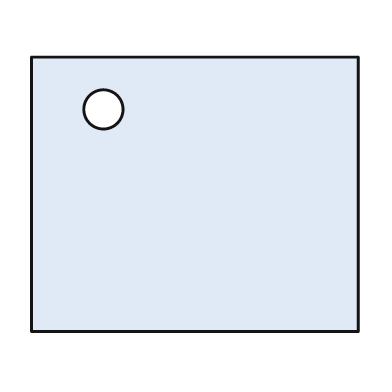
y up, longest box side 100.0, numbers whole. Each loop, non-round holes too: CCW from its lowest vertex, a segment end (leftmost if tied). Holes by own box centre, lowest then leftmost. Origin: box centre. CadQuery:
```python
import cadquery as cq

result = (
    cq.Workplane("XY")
    .moveTo(-50.0, -42.0)
    .lineTo(50.0, -42.0)
    .lineTo(50.0, 42.0)
    .lineTo(-50.0, 42.0)
    .close()
    .moveTo(-28.0, 26.0)
    .circle(6.0)
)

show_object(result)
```